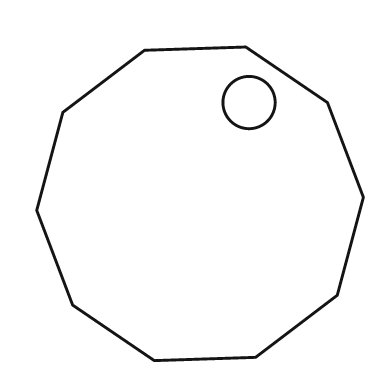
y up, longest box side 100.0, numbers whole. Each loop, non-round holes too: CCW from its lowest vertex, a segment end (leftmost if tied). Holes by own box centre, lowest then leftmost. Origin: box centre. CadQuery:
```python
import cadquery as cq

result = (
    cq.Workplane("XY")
    .moveTo(-14.0, -48.0)
    .lineTo(17.0, -47.0)
    .lineTo(42.0, -28.0)
    .lineTo(50.0, 2.0)
    .lineTo(39.0, 31.0)
    .lineTo(14.0, 48.0)
    .lineTo(-17.0, 47.0)
    .lineTo(-42.0, 28.0)
    .lineTo(-50.0, -2.0)
    .lineTo(-39.0, -31.0)
    .close()
    .moveTo(15.0, 31.0)
    .circle(8.0)
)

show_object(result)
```